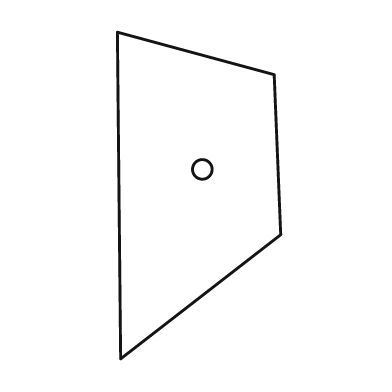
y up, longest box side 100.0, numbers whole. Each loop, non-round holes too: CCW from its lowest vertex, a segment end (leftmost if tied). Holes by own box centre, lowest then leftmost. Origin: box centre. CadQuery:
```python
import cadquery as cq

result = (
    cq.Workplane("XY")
    .moveTo(-24.0, -50.0)
    .lineTo(25.0, -12.0)
    .lineTo(23.0, 37.0)
    .lineTo(-25.0, 50.0)
    .close()
    .moveTo(1.0, 8.0)
    .circle(3.0)
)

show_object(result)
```